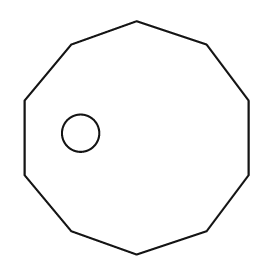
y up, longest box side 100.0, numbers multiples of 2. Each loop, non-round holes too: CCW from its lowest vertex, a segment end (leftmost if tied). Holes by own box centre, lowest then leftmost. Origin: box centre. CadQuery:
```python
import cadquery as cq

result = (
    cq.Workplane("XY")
    .moveTo(0.0, -50.0)
    .lineTo(30.0, -40.0)
    .lineTo(48.0, -16.0)
    .lineTo(48.0, 16.0)
    .lineTo(30.0, 40.0)
    .lineTo(0.0, 50.0)
    .lineTo(-28.0, 40.0)
    .lineTo(-48.0, 16.0)
    .lineTo(-48.0, -16.0)
    .lineTo(-28.0, -40.0)
    .close()
    .moveTo(-24.0, 2.0)
    .circle(8.0)
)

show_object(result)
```